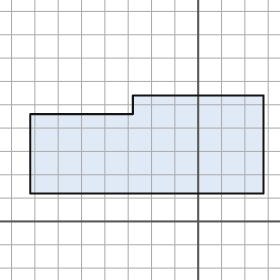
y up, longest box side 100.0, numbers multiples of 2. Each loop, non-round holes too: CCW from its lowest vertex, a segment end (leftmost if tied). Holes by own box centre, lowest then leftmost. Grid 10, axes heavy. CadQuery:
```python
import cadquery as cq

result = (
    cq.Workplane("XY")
    .moveTo(-72.0, 12.0)
    .lineTo(28.0, 12.0)
    .lineTo(28.0, 54.0)
    .lineTo(-28.0, 54.0)
    .lineTo(-28.0, 46.0)
    .lineTo(-72.0, 46.0)
    .close()
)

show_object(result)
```